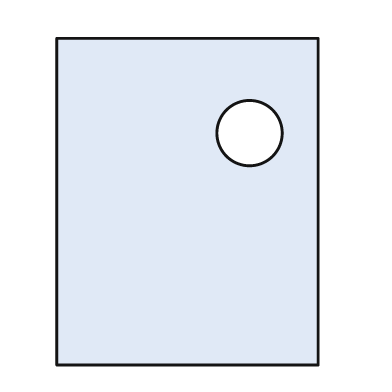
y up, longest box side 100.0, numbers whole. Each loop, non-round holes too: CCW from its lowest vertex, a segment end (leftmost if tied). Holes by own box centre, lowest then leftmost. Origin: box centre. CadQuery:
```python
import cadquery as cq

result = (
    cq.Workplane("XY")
    .moveTo(-40.0, -50.0)
    .lineTo(40.0, -50.0)
    .lineTo(40.0, 50.0)
    .lineTo(-40.0, 50.0)
    .close()
    .moveTo(19.0, 21.0)
    .circle(10.0)
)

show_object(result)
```